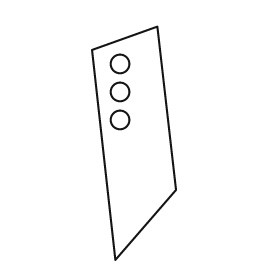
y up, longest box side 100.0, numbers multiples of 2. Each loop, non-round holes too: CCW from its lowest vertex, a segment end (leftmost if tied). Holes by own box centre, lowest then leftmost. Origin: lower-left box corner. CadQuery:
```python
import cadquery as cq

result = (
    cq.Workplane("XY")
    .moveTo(10.0, 0.0)
    .lineTo(36.0, 30.0)
    .lineTo(28.0, 100.0)
    .lineTo(0.0, 90.0)
    .close()
    .moveTo(12.0, 60.0)
    .circle(4.0)
    .moveTo(12.0, 72.0)
    .circle(4.0)
    .moveTo(12.0, 84.0)
    .circle(4.0)
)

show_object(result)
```